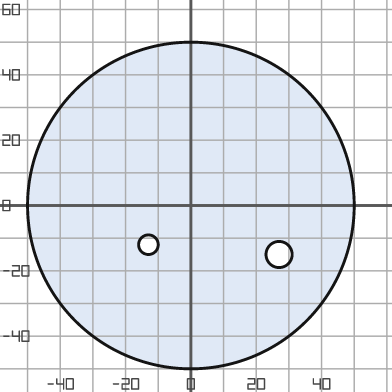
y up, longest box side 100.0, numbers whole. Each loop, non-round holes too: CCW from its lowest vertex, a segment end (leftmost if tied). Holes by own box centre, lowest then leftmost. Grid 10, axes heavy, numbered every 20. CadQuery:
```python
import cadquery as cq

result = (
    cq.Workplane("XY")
    .moveTo(0.0, 0.0)
    .circle(50.0)
    .moveTo(27.0, -15.0)
    .circle(4.0)
    .moveTo(-13.0, -12.0)
    .circle(3.0)
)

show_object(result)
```